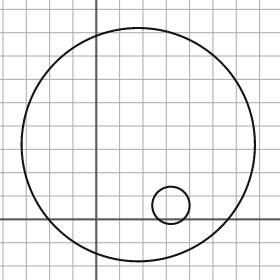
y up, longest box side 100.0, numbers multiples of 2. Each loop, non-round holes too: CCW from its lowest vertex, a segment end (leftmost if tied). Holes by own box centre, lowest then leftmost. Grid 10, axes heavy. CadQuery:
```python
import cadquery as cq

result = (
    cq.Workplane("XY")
    .moveTo(18.0, 32.0)
    .circle(50.0)
    .moveTo(32.0, 6.0)
    .circle(8.0)
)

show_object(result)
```